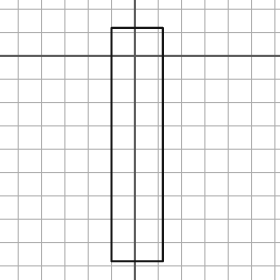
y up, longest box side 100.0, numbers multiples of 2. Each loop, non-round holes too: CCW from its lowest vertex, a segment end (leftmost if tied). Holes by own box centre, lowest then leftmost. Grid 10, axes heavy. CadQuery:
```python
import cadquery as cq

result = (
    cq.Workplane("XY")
    .moveTo(-10.0, -88.0)
    .lineTo(12.0, -88.0)
    .lineTo(12.0, 12.0)
    .lineTo(-10.0, 12.0)
    .close()
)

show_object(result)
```